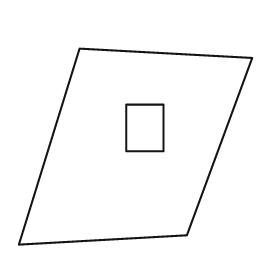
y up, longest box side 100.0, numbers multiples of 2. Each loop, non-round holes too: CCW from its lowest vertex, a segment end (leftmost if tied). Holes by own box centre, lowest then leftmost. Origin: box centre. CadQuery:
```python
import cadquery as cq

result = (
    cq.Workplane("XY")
    .moveTo(-50.0, -42.0)
    .lineTo(22.0, -38.0)
    .lineTo(50.0, 38.0)
    .lineTo(-24.0, 42.0)
    .close()
    .moveTo(-4.0, -2.0)
    .lineTo(12.0, -2.0)
    .lineTo(12.0, 18.0)
    .lineTo(-4.0, 18.0)
    .close()
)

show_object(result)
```